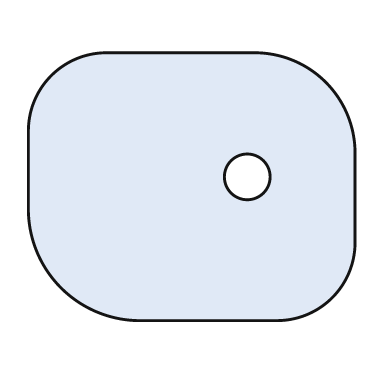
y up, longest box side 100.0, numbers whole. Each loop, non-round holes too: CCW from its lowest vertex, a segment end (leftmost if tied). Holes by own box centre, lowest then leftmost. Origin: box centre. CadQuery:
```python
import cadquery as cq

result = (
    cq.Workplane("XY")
    .moveTo(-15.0, -41.0)
    .lineTo(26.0, -41.0)
    .threePointArc((43.0, -34.0), (50.0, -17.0))
    .lineTo(50.0, 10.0)
    .threePointArc((41.0, 32.0), (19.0, 41.0))
    .lineTo(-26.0, 41.0)
    .threePointArc((-43.0, 34.0), (-50.0, 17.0))
    .lineTo(-50.0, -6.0)
    .threePointArc((-40.0, -31.0), (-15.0, -41.0))
    .close()
    .moveTo(17.0, 3.0)
    .circle(7.0)
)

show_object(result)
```